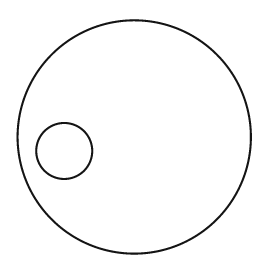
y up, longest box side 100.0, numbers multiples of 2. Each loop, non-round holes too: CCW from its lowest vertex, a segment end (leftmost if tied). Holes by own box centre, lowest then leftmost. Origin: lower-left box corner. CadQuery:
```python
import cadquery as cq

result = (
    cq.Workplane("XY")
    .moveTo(50.0, 50.0)
    .circle(50.0)
    .moveTo(20.0, 44.0)
    .circle(12.0)
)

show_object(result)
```